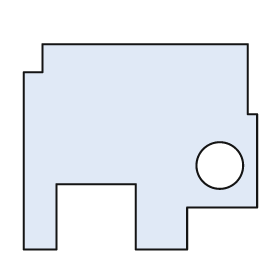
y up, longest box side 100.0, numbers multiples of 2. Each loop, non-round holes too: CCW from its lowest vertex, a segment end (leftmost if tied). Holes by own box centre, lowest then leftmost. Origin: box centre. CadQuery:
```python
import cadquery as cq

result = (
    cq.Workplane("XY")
    .moveTo(-50.0, -44.0)
    .lineTo(-36.0, -44.0)
    .lineTo(-36.0, -16.0)
    .lineTo(-2.0, -16.0)
    .lineTo(-2.0, -44.0)
    .lineTo(20.0, -44.0)
    .lineTo(20.0, -26.0)
    .lineTo(50.0, -26.0)
    .lineTo(50.0, 14.0)
    .lineTo(46.0, 14.0)
    .lineTo(46.0, 44.0)
    .lineTo(-42.0, 44.0)
    .lineTo(-42.0, 32.0)
    .lineTo(-50.0, 32.0)
    .close()
    .moveTo(34.0, -8.0)
    .circle(10.0)
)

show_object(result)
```